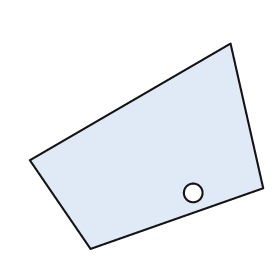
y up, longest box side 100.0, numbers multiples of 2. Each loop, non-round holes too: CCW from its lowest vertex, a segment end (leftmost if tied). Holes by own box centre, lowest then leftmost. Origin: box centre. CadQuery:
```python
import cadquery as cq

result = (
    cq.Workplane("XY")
    .moveTo(-24.0, -44.0)
    .lineTo(50.0, -18.0)
    .lineTo(36.0, 44.0)
    .lineTo(-50.0, -6.0)
    .close()
    .moveTo(20.0, -20.0)
    .circle(4.0)
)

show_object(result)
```